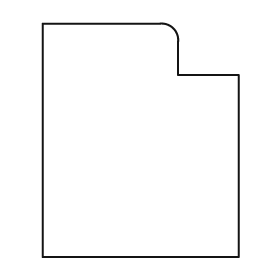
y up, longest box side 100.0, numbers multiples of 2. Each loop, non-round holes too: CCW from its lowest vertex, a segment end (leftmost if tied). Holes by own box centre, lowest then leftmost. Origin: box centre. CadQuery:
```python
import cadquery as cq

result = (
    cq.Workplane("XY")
    .moveTo(-42.0, -50.0)
    .lineTo(42.0, -50.0)
    .lineTo(42.0, 28.0)
    .lineTo(16.0, 28.0)
    .lineTo(16.0, 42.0)
    .threePointArc((14.0, 48.0), (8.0, 50.0))
    .lineTo(-42.0, 50.0)
    .close()
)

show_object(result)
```